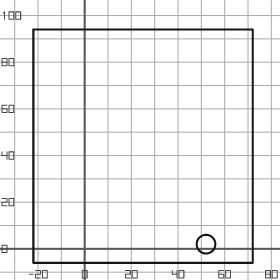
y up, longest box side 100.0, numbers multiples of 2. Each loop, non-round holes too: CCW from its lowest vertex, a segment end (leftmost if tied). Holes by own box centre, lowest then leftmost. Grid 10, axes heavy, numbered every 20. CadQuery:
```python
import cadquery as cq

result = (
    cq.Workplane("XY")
    .moveTo(-22.0, -6.0)
    .lineTo(72.0, -6.0)
    .lineTo(72.0, 94.0)
    .lineTo(-22.0, 94.0)
    .close()
    .moveTo(52.0, 2.0)
    .circle(4.0)
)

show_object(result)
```